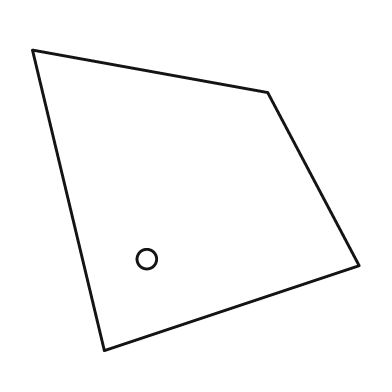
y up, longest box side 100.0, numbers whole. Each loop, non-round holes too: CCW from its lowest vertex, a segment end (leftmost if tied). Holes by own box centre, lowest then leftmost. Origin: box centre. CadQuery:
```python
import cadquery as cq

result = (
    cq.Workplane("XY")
    .moveTo(-28.0, -46.0)
    .lineTo(50.0, -20.0)
    .lineTo(22.0, 33.0)
    .lineTo(-50.0, 46.0)
    .close()
    .moveTo(-15.0, -18.0)
    .circle(3.0)
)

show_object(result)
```